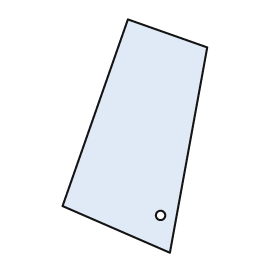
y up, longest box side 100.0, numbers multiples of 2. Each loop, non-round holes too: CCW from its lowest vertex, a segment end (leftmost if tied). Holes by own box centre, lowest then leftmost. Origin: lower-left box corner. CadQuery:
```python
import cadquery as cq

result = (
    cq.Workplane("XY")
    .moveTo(46.0, 0.0)
    .lineTo(62.0, 88.0)
    .lineTo(28.0, 100.0)
    .lineTo(0.0, 20.0)
    .close()
    .moveTo(42.0, 16.0)
    .circle(2.0)
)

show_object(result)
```